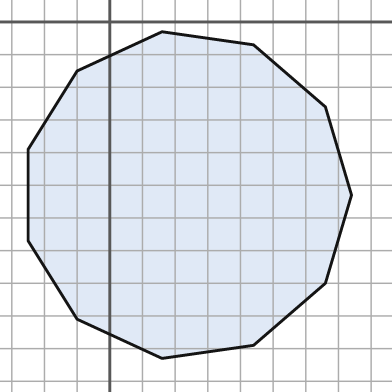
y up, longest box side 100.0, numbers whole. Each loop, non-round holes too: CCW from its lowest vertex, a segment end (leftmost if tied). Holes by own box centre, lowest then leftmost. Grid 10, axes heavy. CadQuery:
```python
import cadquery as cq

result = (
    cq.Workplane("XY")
    .moveTo(16.0, -103.0)
    .lineTo(44.0, -99.0)
    .lineTo(66.0, -80.0)
    .lineTo(74.0, -53.0)
    .lineTo(66.0, -26.0)
    .lineTo(44.0, -7.0)
    .lineTo(16.0, -3.0)
    .lineTo(-10.0, -15.0)
    .lineTo(-25.0, -39.0)
    .lineTo(-25.0, -67.0)
    .lineTo(-10.0, -91.0)
    .close()
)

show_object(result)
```